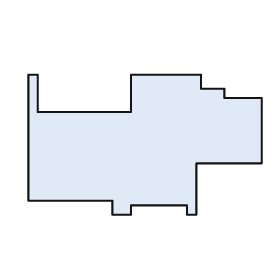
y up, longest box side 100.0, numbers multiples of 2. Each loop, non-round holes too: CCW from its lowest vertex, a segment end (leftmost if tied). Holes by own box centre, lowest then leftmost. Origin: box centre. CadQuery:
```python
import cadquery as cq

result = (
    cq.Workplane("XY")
    .moveTo(-14.0, -30.0)
    .lineTo(-6.0, -30.0)
    .lineTo(-6.0, -26.0)
    .lineTo(18.0, -26.0)
    .lineTo(18.0, -30.0)
    .lineTo(22.0, -30.0)
    .lineTo(22.0, -8.0)
    .lineTo(50.0, -8.0)
    .lineTo(50.0, 20.0)
    .lineTo(34.0, 20.0)
    .lineTo(34.0, 24.0)
    .lineTo(24.0, 24.0)
    .lineTo(24.0, 30.0)
    .lineTo(-6.0, 30.0)
    .lineTo(-6.0, 14.0)
    .lineTo(-46.0, 14.0)
    .lineTo(-46.0, 30.0)
    .lineTo(-50.0, 30.0)
    .lineTo(-50.0, -24.0)
    .lineTo(-14.0, -24.0)
    .close()
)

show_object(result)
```